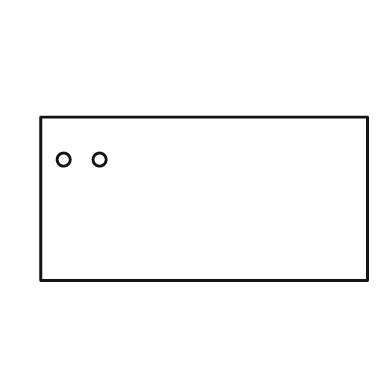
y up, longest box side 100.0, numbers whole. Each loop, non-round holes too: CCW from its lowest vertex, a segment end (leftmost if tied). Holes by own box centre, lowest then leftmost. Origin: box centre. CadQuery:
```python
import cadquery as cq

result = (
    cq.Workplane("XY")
    .moveTo(-50.0, -25.0)
    .lineTo(50.0, -25.0)
    .lineTo(50.0, 25.0)
    .lineTo(-50.0, 25.0)
    .close()
    .moveTo(-43.0, 12.0)
    .circle(2.0)
    .moveTo(-32.0, 12.0)
    .circle(2.0)
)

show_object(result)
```